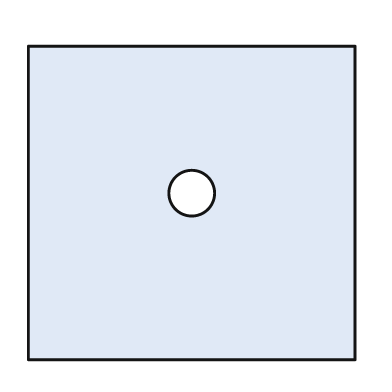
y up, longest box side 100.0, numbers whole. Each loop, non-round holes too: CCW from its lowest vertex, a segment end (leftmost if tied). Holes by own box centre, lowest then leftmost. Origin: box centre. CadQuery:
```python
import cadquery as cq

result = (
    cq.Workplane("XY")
    .moveTo(-50.0, -48.0)
    .lineTo(50.0, -48.0)
    .lineTo(50.0, 48.0)
    .lineTo(-50.0, 48.0)
    .close()
    .moveTo(0.0, 3.0)
    .circle(7.0)
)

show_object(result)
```